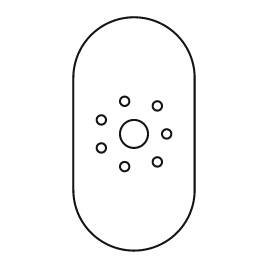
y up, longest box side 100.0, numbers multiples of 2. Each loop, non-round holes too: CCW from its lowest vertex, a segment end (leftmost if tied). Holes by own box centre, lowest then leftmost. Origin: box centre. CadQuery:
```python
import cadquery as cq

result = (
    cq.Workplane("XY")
    .moveTo(-26.0, -24.0)
    .threePointArc((0.0, -50.0), (26.0, -24.0))
    .lineTo(26.0, 24.0)
    .threePointArc((0.0, 50.0), (-26.0, 24.0))
    .close()
    .moveTo(-4.0, -14.0)
    .circle(2.0)
    .moveTo(10.0, -12.0)
    .circle(2.0)
    .moveTo(-14.0, -6.0)
    .circle(2.0)
    .moveTo(0.0, 0.0)
    .circle(6.0)
    .moveTo(14.0, 0.0)
    .circle(2.0)
    .moveTo(-14.0, 6.0)
    .circle(2.0)
    .moveTo(10.0, 12.0)
    .circle(2.0)
    .moveTo(-4.0, 14.0)
    .circle(2.0)
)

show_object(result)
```